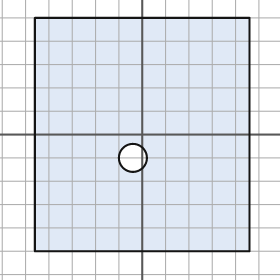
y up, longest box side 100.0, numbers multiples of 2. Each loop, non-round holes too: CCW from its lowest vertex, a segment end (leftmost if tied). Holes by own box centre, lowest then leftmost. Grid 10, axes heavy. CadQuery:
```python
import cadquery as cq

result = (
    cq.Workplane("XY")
    .moveTo(-46.0, -50.0)
    .lineTo(46.0, -50.0)
    .lineTo(46.0, 50.0)
    .lineTo(-46.0, 50.0)
    .close()
    .moveTo(-4.0, -10.0)
    .circle(6.0)
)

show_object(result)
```